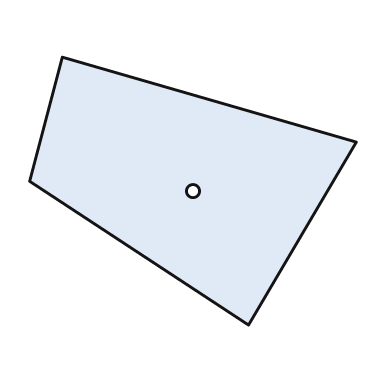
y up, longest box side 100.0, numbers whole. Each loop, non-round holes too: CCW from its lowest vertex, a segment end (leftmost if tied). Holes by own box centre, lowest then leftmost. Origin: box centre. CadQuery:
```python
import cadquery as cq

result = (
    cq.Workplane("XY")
    .moveTo(17.0, -41.0)
    .lineTo(50.0, 15.0)
    .lineTo(-40.0, 41.0)
    .lineTo(-50.0, 3.0)
    .close()
    .moveTo(0.0, 0.0)
    .circle(2.0)
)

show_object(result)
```